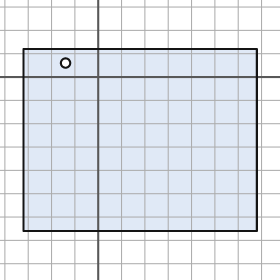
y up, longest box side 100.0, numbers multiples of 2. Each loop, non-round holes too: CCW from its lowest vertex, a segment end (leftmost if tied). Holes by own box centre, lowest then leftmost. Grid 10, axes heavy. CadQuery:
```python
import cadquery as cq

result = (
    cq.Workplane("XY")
    .moveTo(-32.0, -66.0)
    .lineTo(68.0, -66.0)
    .lineTo(68.0, 12.0)
    .lineTo(-32.0, 12.0)
    .close()
    .moveTo(-14.0, 6.0)
    .circle(2.0)
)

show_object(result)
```